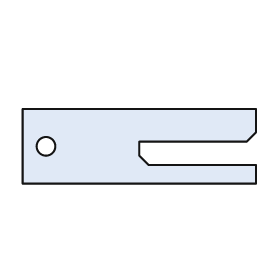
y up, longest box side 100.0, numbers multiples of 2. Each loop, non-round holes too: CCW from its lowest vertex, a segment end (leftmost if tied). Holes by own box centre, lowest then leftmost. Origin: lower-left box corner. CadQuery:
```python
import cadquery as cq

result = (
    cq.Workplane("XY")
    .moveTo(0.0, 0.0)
    .lineTo(100.0, 0.0)
    .lineTo(100.0, 8.0)
    .lineTo(54.0, 8.0)
    .lineTo(50.0, 12.0)
    .lineTo(50.0, 18.0)
    .lineTo(96.0, 18.0)
    .lineTo(100.0, 22.0)
    .lineTo(100.0, 32.0)
    .lineTo(0.0, 32.0)
    .close()
    .moveTo(10.0, 16.0)
    .circle(4.0)
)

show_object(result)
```